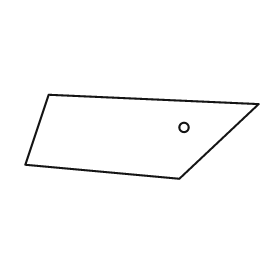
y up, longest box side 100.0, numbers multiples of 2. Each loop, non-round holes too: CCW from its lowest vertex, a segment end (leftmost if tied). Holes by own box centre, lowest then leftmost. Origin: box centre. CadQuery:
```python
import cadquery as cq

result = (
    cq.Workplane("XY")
    .moveTo(16.0, -18.0)
    .lineTo(50.0, 14.0)
    .lineTo(-40.0, 18.0)
    .lineTo(-50.0, -12.0)
    .close()
    .moveTo(18.0, 4.0)
    .circle(2.0)
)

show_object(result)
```